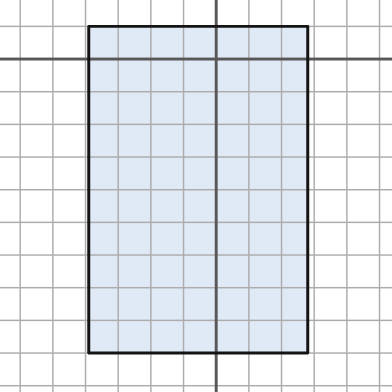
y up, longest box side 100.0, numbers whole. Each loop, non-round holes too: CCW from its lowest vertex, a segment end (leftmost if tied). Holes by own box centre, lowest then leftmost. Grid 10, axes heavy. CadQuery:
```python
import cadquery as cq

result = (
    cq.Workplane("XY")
    .moveTo(-39.0, -90.0)
    .lineTo(28.0, -90.0)
    .lineTo(28.0, 10.0)
    .lineTo(-39.0, 10.0)
    .close()
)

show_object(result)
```